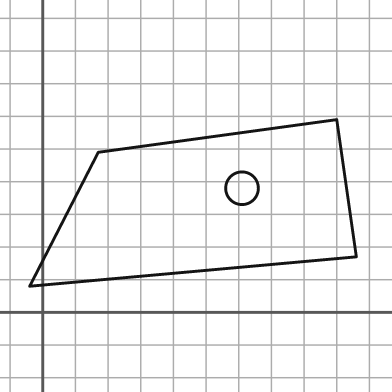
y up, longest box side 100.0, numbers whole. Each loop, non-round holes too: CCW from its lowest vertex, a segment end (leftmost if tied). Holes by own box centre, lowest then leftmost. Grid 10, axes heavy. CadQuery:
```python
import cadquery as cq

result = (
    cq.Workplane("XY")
    .moveTo(-4.0, 8.0)
    .lineTo(96.0, 17.0)
    .lineTo(90.0, 59.0)
    .lineTo(17.0, 49.0)
    .close()
    .moveTo(61.0, 38.0)
    .circle(5.0)
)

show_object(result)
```